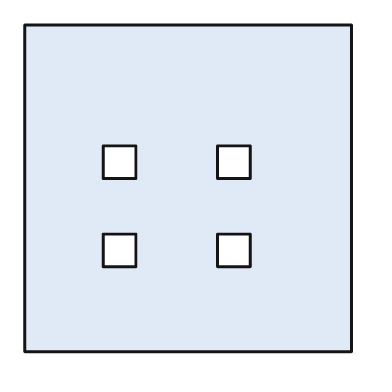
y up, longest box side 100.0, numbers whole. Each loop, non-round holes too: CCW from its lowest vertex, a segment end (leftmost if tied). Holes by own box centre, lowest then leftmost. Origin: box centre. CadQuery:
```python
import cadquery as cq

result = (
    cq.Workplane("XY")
    .moveTo(-50.0, -50.0)
    .lineTo(50.0, -50.0)
    .lineTo(50.0, 50.0)
    .lineTo(-50.0, 50.0)
    .close()
    .moveTo(-26.0, -24.0)
    .lineTo(-16.0, -24.0)
    .lineTo(-16.0, -14.0)
    .lineTo(-26.0, -14.0)
    .close()
    .moveTo(9.0, -24.0)
    .lineTo(19.0, -24.0)
    .lineTo(19.0, -14.0)
    .lineTo(9.0, -14.0)
    .close()
    .moveTo(-26.0, 3.0)
    .lineTo(-16.0, 3.0)
    .lineTo(-16.0, 13.0)
    .lineTo(-26.0, 13.0)
    .close()
    .moveTo(9.0, 3.0)
    .lineTo(19.0, 3.0)
    .lineTo(19.0, 13.0)
    .lineTo(9.0, 13.0)
    .close()
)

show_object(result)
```